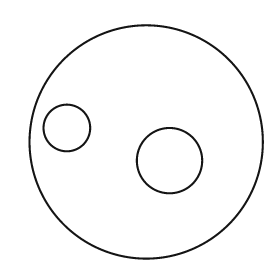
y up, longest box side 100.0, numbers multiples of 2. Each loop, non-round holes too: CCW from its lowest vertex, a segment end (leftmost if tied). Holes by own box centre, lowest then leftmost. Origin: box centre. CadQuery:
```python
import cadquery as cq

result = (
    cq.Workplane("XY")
    .moveTo(0.0, 0.0)
    .circle(50.0)
    .moveTo(10.0, -8.0)
    .circle(14.0)
    .moveTo(-34.0, 6.0)
    .circle(10.0)
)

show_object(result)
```